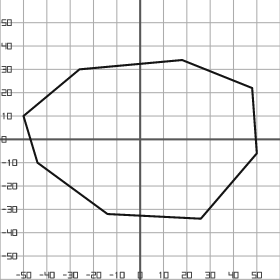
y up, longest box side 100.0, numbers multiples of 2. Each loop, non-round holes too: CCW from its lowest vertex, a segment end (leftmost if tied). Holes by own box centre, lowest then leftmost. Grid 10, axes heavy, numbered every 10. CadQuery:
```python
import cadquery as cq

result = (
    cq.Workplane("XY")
    .moveTo(26.0, -34.0)
    .lineTo(50.0, -6.0)
    .lineTo(48.0, 22.0)
    .lineTo(18.0, 34.0)
    .lineTo(-26.0, 30.0)
    .lineTo(-50.0, 10.0)
    .lineTo(-44.0, -10.0)
    .lineTo(-14.0, -32.0)
    .close()
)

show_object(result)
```